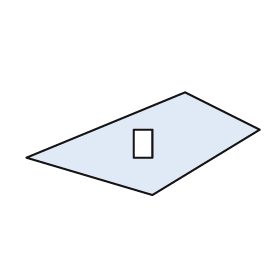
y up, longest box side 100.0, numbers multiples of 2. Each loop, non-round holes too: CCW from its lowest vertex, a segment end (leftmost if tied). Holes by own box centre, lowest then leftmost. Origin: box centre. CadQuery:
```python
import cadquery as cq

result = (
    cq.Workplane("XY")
    .moveTo(4.0, -22.0)
    .lineTo(50.0, 6.0)
    .lineTo(18.0, 22.0)
    .lineTo(-50.0, -6.0)
    .close()
    .moveTo(-4.0, -6.0)
    .lineTo(4.0, -6.0)
    .lineTo(4.0, 6.0)
    .lineTo(-4.0, 6.0)
    .close()
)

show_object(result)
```